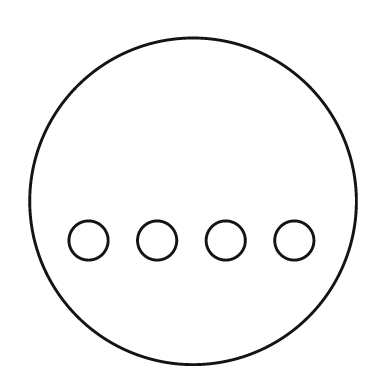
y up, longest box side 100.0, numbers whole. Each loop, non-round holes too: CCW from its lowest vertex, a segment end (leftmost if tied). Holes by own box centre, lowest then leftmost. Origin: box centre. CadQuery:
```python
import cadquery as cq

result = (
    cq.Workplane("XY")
    .moveTo(0.0, 0.0)
    .circle(50.0)
    .moveTo(-32.0, -12.0)
    .circle(6.0)
    .moveTo(-11.0, -12.0)
    .circle(6.0)
    .moveTo(10.0, -12.0)
    .circle(6.0)
    .moveTo(31.0, -12.0)
    .circle(6.0)
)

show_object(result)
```